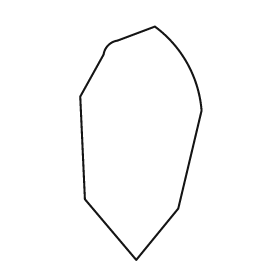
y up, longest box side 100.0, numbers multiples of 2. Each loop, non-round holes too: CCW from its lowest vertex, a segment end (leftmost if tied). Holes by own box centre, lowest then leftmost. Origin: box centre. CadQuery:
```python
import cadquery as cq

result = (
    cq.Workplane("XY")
    .moveTo(-2.0, -50.0)
    .lineTo(16.0, -28.0)
    .lineTo(26.0, 14.0)
    .threePointArc((20.0, 34.0), (6.0, 50.0))
    .lineTo(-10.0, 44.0)
    .threePointArc((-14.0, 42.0), (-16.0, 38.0))
    .lineTo(-26.0, 20.0)
    .lineTo(-24.0, -24.0)
    .close()
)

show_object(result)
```